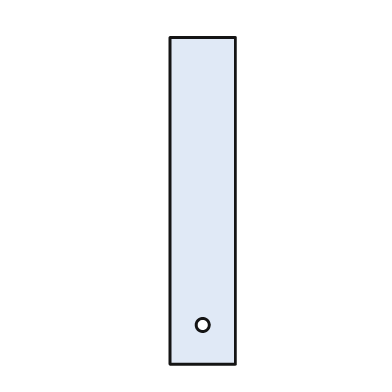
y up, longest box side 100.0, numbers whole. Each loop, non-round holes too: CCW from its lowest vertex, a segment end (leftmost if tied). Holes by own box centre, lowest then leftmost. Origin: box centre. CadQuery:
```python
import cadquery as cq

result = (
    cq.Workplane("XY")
    .moveTo(-10.0, -50.0)
    .lineTo(10.0, -50.0)
    .lineTo(10.0, 50.0)
    .lineTo(-10.0, 50.0)
    .close()
    .moveTo(0.0, -38.0)
    .circle(2.0)
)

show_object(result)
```